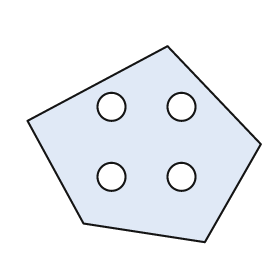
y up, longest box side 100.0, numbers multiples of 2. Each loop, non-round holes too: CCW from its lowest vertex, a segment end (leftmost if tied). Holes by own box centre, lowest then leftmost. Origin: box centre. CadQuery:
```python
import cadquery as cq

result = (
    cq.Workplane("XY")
    .moveTo(26.0, -42.0)
    .lineTo(50.0, 0.0)
    .lineTo(10.0, 42.0)
    .lineTo(-50.0, 10.0)
    .lineTo(-26.0, -34.0)
    .close()
    .moveTo(-14.0, -14.0)
    .circle(6.0)
    .moveTo(16.0, -14.0)
    .circle(6.0)
    .moveTo(-14.0, 16.0)
    .circle(6.0)
    .moveTo(16.0, 16.0)
    .circle(6.0)
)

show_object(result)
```